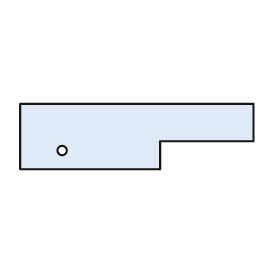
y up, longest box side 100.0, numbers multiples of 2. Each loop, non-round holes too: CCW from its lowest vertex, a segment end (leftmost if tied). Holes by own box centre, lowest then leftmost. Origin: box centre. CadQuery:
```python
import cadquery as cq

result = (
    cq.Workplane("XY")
    .moveTo(-50.0, -14.0)
    .lineTo(10.0, -14.0)
    .lineTo(10.0, -2.0)
    .lineTo(50.0, -2.0)
    .lineTo(50.0, 14.0)
    .lineTo(-50.0, 14.0)
    .close()
    .moveTo(-32.0, -6.0)
    .circle(2.0)
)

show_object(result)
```